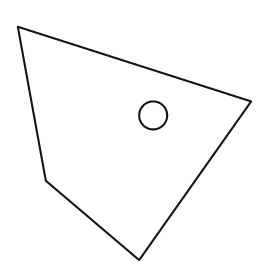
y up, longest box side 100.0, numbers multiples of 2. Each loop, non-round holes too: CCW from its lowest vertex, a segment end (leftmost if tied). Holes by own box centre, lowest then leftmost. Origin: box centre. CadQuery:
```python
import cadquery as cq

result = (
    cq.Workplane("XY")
    .moveTo(2.0, -50.0)
    .lineTo(50.0, 18.0)
    .lineTo(-50.0, 50.0)
    .lineTo(-38.0, -16.0)
    .close()
    .moveTo(8.0, 12.0)
    .circle(6.0)
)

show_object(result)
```